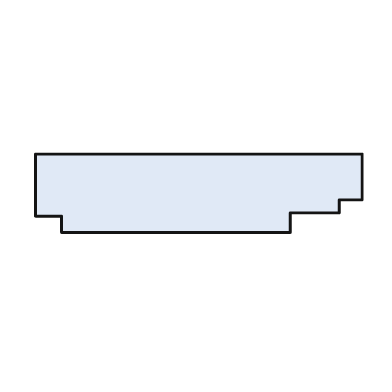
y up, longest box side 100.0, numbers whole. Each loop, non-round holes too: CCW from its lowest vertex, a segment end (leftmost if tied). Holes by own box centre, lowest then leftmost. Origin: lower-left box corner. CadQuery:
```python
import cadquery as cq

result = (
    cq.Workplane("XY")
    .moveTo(8.0, 0.0)
    .lineTo(78.0, 0.0)
    .lineTo(78.0, 6.0)
    .lineTo(93.0, 6.0)
    .lineTo(93.0, 10.0)
    .lineTo(100.0, 10.0)
    .lineTo(100.0, 24.0)
    .lineTo(0.0, 24.0)
    .lineTo(0.0, 5.0)
    .lineTo(8.0, 5.0)
    .close()
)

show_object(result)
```